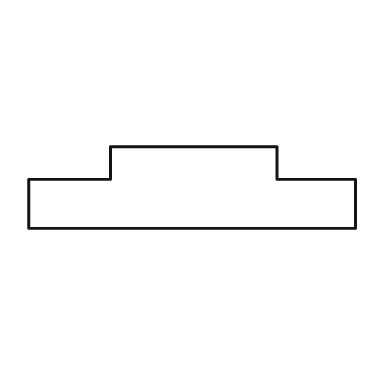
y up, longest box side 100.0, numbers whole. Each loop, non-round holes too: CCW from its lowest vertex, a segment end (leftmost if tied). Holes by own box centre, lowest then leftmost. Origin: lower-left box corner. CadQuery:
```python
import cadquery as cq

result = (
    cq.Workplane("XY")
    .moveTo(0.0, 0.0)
    .lineTo(100.0, 0.0)
    .lineTo(100.0, 15.0)
    .lineTo(76.0, 15.0)
    .lineTo(76.0, 25.0)
    .lineTo(25.0, 25.0)
    .lineTo(25.0, 15.0)
    .lineTo(0.0, 15.0)
    .close()
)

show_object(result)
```